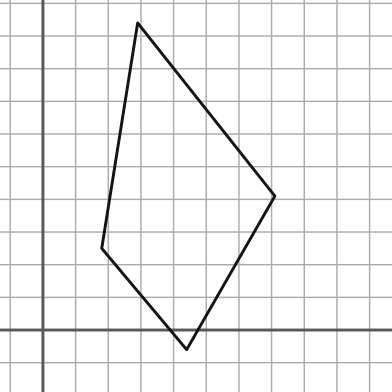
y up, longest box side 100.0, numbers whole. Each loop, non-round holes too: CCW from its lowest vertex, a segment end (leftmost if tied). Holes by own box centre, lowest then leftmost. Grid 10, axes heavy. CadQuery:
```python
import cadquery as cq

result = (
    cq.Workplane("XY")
    .moveTo(44.0, -6.0)
    .lineTo(71.0, 41.0)
    .lineTo(29.0, 94.0)
    .lineTo(18.0, 25.0)
    .close()
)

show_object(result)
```